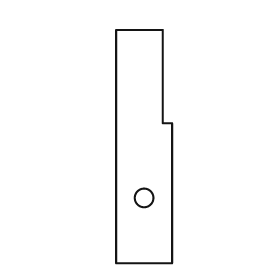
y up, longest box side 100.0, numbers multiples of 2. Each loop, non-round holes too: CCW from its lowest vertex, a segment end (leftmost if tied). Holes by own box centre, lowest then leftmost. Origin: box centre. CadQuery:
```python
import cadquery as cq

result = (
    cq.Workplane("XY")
    .moveTo(-12.0, -50.0)
    .lineTo(12.0, -50.0)
    .lineTo(12.0, 10.0)
    .lineTo(8.0, 10.0)
    .lineTo(8.0, 50.0)
    .lineTo(-12.0, 50.0)
    .close()
    .moveTo(0.0, -22.0)
    .circle(4.0)
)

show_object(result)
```